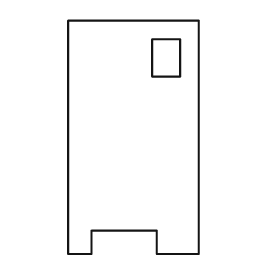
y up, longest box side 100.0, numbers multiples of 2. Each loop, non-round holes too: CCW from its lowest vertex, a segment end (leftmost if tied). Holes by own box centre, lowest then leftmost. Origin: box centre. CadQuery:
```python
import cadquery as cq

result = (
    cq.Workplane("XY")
    .moveTo(-28.0, -50.0)
    .lineTo(-18.0, -50.0)
    .lineTo(-18.0, -40.0)
    .lineTo(10.0, -40.0)
    .lineTo(10.0, -50.0)
    .lineTo(28.0, -50.0)
    .lineTo(28.0, 50.0)
    .lineTo(-28.0, 50.0)
    .close()
    .moveTo(8.0, 26.0)
    .lineTo(20.0, 26.0)
    .lineTo(20.0, 42.0)
    .lineTo(8.0, 42.0)
    .close()
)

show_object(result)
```